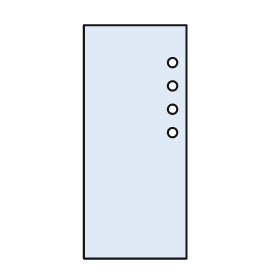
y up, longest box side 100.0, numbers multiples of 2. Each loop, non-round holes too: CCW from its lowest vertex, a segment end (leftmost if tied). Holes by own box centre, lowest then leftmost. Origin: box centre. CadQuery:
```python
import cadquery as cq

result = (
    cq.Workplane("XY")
    .moveTo(-22.0, -50.0)
    .lineTo(22.0, -50.0)
    .lineTo(22.0, 50.0)
    .lineTo(-22.0, 50.0)
    .close()
    .moveTo(16.0, 4.0)
    .circle(2.0)
    .moveTo(16.0, 14.0)
    .circle(2.0)
    .moveTo(16.0, 24.0)
    .circle(2.0)
    .moveTo(16.0, 34.0)
    .circle(2.0)
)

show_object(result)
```